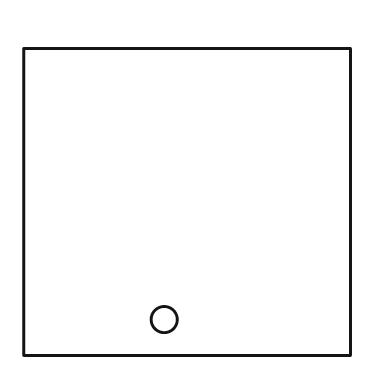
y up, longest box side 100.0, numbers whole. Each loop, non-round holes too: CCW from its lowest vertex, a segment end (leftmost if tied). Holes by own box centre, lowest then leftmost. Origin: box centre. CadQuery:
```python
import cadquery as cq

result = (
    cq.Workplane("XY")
    .moveTo(-50.0, -47.0)
    .lineTo(50.0, -47.0)
    .lineTo(50.0, 47.0)
    .lineTo(-50.0, 47.0)
    .close()
    .moveTo(-7.0, -36.0)
    .circle(4.0)
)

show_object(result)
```